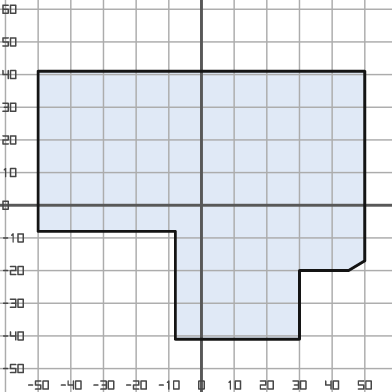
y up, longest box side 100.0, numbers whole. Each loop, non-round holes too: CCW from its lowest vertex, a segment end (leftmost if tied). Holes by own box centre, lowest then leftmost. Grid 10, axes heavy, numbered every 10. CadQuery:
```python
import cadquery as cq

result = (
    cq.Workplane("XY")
    .moveTo(-8.0, -41.0)
    .lineTo(30.0, -41.0)
    .lineTo(30.0, -20.0)
    .lineTo(45.0, -20.0)
    .lineTo(50.0, -17.0)
    .lineTo(50.0, 41.0)
    .lineTo(-50.0, 41.0)
    .lineTo(-50.0, -8.0)
    .lineTo(-8.0, -8.0)
    .close()
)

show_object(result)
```